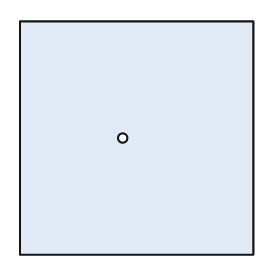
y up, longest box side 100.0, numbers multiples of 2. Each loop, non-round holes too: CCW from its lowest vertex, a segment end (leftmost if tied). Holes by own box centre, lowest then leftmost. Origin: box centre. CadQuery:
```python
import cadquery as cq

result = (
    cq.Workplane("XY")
    .moveTo(-50.0, -50.0)
    .lineTo(50.0, -50.0)
    .lineTo(50.0, 50.0)
    .lineTo(-50.0, 50.0)
    .close()
    .moveTo(-6.0, 0.0)
    .circle(2.0)
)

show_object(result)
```